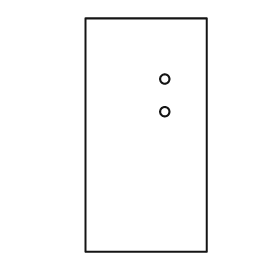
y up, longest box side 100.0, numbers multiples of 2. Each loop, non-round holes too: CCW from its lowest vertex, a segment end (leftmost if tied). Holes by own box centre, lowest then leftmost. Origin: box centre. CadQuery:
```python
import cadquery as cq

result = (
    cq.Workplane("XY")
    .moveTo(-26.0, -50.0)
    .lineTo(26.0, -50.0)
    .lineTo(26.0, 50.0)
    .lineTo(-26.0, 50.0)
    .close()
    .moveTo(8.0, 10.0)
    .circle(2.0)
    .moveTo(8.0, 24.0)
    .circle(2.0)
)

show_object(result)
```